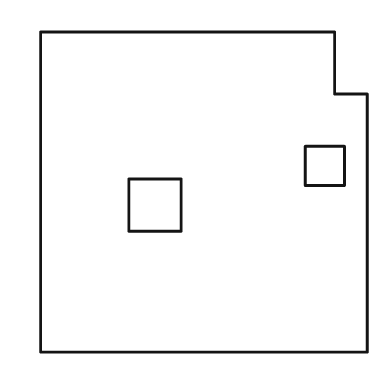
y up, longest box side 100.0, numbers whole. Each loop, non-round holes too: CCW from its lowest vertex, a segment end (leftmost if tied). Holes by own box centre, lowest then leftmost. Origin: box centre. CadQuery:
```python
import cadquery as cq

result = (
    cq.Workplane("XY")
    .moveTo(-50.0, -49.0)
    .lineTo(50.0, -49.0)
    .lineTo(50.0, 30.0)
    .lineTo(40.0, 30.0)
    .lineTo(40.0, 49.0)
    .lineTo(-50.0, 49.0)
    .close()
    .moveTo(-23.0, -12.0)
    .lineTo(-7.0, -12.0)
    .lineTo(-7.0, 4.0)
    .lineTo(-23.0, 4.0)
    .close()
    .moveTo(31.0, 2.0)
    .lineTo(43.0, 2.0)
    .lineTo(43.0, 14.0)
    .lineTo(31.0, 14.0)
    .close()
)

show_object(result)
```